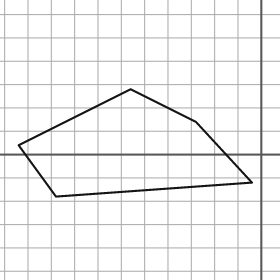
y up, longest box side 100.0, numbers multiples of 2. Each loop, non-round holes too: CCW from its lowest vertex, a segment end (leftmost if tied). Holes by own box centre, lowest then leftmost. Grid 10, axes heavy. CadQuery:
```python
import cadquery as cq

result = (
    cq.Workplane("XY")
    .moveTo(-88.0, -18.0)
    .lineTo(-4.0, -12.0)
    .lineTo(-28.0, 14.0)
    .lineTo(-56.0, 28.0)
    .lineTo(-104.0, 4.0)
    .close()
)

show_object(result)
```